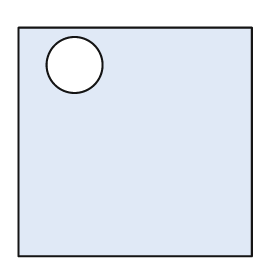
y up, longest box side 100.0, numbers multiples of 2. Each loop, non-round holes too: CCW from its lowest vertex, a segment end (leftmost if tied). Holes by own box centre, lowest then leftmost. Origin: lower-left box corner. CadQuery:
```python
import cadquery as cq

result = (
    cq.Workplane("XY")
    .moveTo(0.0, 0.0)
    .lineTo(100.0, 0.0)
    .lineTo(100.0, 98.0)
    .lineTo(0.0, 98.0)
    .close()
    .moveTo(24.0, 82.0)
    .circle(12.0)
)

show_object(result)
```